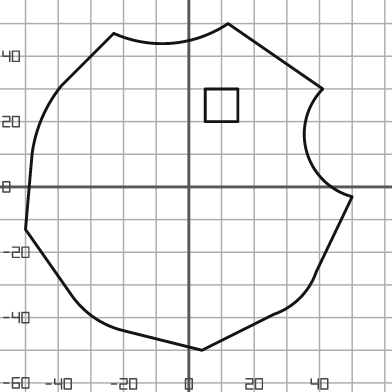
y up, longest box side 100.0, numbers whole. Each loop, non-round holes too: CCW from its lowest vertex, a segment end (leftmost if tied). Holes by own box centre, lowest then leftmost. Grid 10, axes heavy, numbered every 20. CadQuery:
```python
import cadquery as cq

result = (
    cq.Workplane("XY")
    .moveTo(4.0, -50.0)
    .lineTo(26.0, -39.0)
    .threePointArc((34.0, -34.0), (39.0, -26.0))
    .lineTo(50.0, -3.0)
    .threePointArc((36.0, 11.0), (41.0, 30.0))
    .lineTo(12.0, 50.0)
    .threePointArc((-5.0, 44.0), (-23.0, 47.0))
    .lineTo(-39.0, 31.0)
    .threePointArc((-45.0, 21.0), (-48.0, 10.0))
    .lineTo(-50.0, -13.0)
    .lineTo(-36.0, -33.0)
    .threePointArc((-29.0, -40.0), (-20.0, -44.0))
    .close()
    .moveTo(5.0, 20.0)
    .lineTo(15.0, 20.0)
    .lineTo(15.0, 30.0)
    .lineTo(5.0, 30.0)
    .close()
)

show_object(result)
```